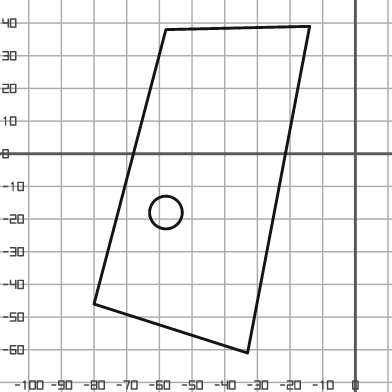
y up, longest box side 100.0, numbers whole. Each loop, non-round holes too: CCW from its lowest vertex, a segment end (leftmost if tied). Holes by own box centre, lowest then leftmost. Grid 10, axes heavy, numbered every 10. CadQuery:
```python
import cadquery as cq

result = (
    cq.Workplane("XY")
    .moveTo(-33.0, -61.0)
    .lineTo(-14.0, 39.0)
    .lineTo(-58.0, 38.0)
    .lineTo(-80.0, -46.0)
    .close()
    .moveTo(-58.0, -18.0)
    .circle(5.0)
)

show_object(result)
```